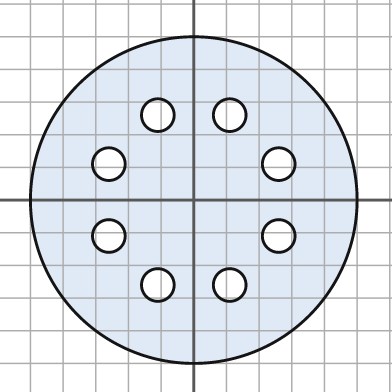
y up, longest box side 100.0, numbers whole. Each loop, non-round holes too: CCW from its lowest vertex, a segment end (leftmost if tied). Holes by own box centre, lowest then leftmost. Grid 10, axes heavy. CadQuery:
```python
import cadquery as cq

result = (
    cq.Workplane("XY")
    .moveTo(0.0, 0.0)
    .circle(50.0)
    .moveTo(-11.0, -26.0)
    .circle(5.0)
    .moveTo(11.0, -26.0)
    .circle(5.0)
    .moveTo(-26.0, -11.0)
    .circle(5.0)
    .moveTo(26.0, -11.0)
    .circle(5.0)
    .moveTo(-26.0, 11.0)
    .circle(5.0)
    .moveTo(26.0, 11.0)
    .circle(5.0)
    .moveTo(-11.0, 26.0)
    .circle(5.0)
    .moveTo(11.0, 26.0)
    .circle(5.0)
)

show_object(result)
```